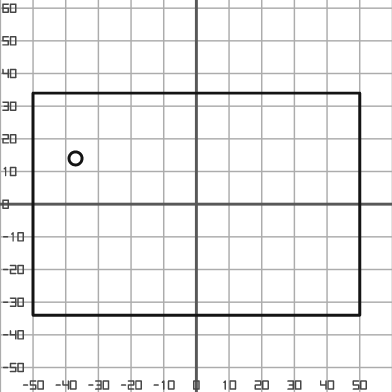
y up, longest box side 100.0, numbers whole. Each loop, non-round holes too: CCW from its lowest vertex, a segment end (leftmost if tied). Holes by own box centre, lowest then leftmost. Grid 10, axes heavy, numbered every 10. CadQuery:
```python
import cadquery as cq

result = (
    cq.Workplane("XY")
    .moveTo(-50.0, -34.0)
    .lineTo(50.0, -34.0)
    .lineTo(50.0, 34.0)
    .lineTo(-50.0, 34.0)
    .close()
    .moveTo(-37.0, 14.0)
    .circle(2.0)
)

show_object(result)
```